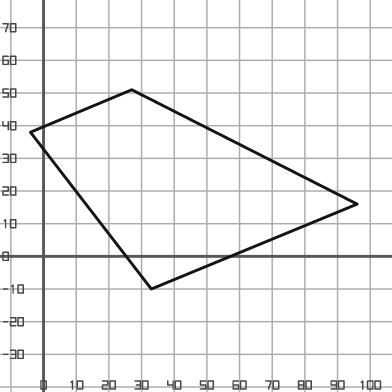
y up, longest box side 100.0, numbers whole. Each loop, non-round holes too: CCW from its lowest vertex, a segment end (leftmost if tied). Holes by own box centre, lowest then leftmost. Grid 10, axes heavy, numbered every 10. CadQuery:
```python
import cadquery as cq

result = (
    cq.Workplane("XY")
    .moveTo(33.0, -10.0)
    .lineTo(96.0, 16.0)
    .lineTo(27.0, 51.0)
    .lineTo(-4.0, 38.0)
    .close()
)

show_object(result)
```